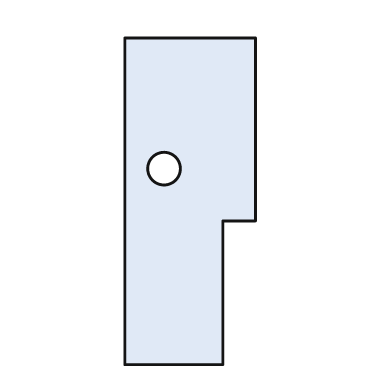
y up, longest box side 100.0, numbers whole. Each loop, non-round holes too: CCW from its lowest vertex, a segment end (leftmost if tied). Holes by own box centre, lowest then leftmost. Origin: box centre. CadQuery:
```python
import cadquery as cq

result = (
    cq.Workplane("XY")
    .moveTo(-20.0, -50.0)
    .lineTo(10.0, -50.0)
    .lineTo(10.0, -6.0)
    .lineTo(20.0, -6.0)
    .lineTo(20.0, 50.0)
    .lineTo(-20.0, 50.0)
    .close()
    .moveTo(-8.0, 10.0)
    .circle(5.0)
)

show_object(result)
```